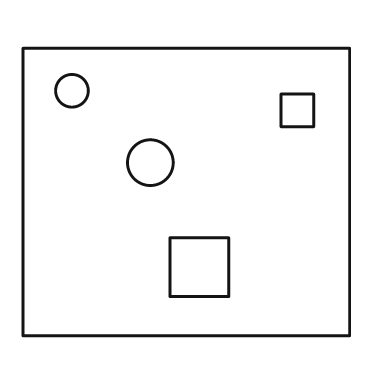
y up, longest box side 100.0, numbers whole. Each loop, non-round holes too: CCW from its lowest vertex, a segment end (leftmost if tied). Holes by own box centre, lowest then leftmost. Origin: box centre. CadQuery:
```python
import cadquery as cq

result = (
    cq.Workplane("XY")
    .moveTo(-50.0, -44.0)
    .lineTo(50.0, -44.0)
    .lineTo(50.0, 44.0)
    .lineTo(-50.0, 44.0)
    .close()
    .moveTo(-5.0, -32.0)
    .lineTo(13.0, -32.0)
    .lineTo(13.0, -14.0)
    .lineTo(-5.0, -14.0)
    .close()
    .moveTo(-11.0, 9.0)
    .circle(7.0)
    .moveTo(29.0, 20.0)
    .lineTo(39.0, 20.0)
    .lineTo(39.0, 30.0)
    .lineTo(29.0, 30.0)
    .close()
    .moveTo(-35.0, 31.0)
    .circle(5.0)
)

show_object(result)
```